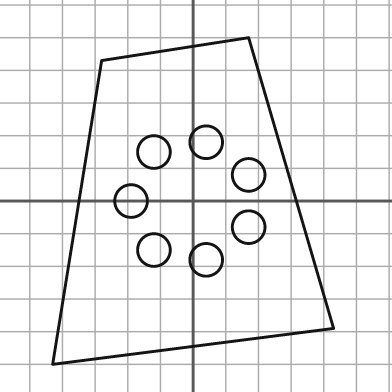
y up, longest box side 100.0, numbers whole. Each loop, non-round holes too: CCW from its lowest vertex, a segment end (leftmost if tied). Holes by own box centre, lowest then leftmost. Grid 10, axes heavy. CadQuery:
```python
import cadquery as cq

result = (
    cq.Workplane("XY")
    .moveTo(-43.0, -50.0)
    .lineTo(43.0, -39.0)
    .lineTo(17.0, 50.0)
    .lineTo(-28.0, 43.0)
    .close()
    .moveTo(4.0, -18.0)
    .circle(5.0)
    .moveTo(-12.0, -15.0)
    .circle(5.0)
    .moveTo(17.0, -8.0)
    .circle(5.0)
    .moveTo(-19.0, 0.0)
    .circle(5.0)
    .moveTo(17.0, 8.0)
    .circle(5.0)
    .moveTo(-12.0, 15.0)
    .circle(5.0)
    .moveTo(4.0, 18.0)
    .circle(5.0)
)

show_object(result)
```